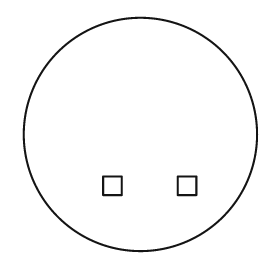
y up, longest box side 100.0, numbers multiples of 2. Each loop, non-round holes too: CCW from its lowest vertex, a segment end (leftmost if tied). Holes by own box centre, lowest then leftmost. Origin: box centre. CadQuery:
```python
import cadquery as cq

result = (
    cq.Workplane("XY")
    .moveTo(0.0, 0.0)
    .circle(50.0)
    .moveTo(-16.0, -26.0)
    .lineTo(-8.0, -26.0)
    .lineTo(-8.0, -18.0)
    .lineTo(-16.0, -18.0)
    .close()
    .moveTo(16.0, -26.0)
    .lineTo(24.0, -26.0)
    .lineTo(24.0, -18.0)
    .lineTo(16.0, -18.0)
    .close()
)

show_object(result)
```